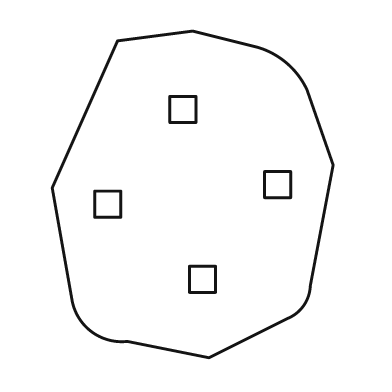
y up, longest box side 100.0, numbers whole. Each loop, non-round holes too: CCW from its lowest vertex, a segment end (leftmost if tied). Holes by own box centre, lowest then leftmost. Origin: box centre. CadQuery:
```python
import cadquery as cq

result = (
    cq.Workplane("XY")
    .moveTo(5.0, -50.0)
    .lineTo(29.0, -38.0)
    .threePointArc((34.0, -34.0), (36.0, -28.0))
    .lineTo(43.0, 9.0)
    .lineTo(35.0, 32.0)
    .threePointArc((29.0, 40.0), (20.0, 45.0))
    .lineTo(0.0, 50.0)
    .lineTo(-23.0, 47.0)
    .lineTo(-43.0, 2.0)
    .lineTo(-37.0, -32.0)
    .threePointArc((-31.0, -42.0), (-20.0, -45.0))
    .close()
    .moveTo(-1.0, -30.0)
    .lineTo(7.0, -30.0)
    .lineTo(7.0, -22.0)
    .lineTo(-1.0, -22.0)
    .close()
    .moveTo(-30.0, -7.0)
    .lineTo(-22.0, -7.0)
    .lineTo(-22.0, 1.0)
    .lineTo(-30.0, 1.0)
    .close()
    .moveTo(22.0, -1.0)
    .lineTo(30.0, -1.0)
    .lineTo(30.0, 7.0)
    .lineTo(22.0, 7.0)
    .close()
    .moveTo(-7.0, 22.0)
    .lineTo(1.0, 22.0)
    .lineTo(1.0, 30.0)
    .lineTo(-7.0, 30.0)
    .close()
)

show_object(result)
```